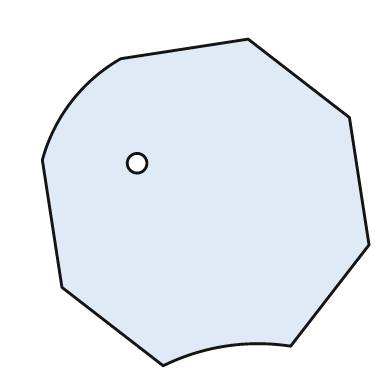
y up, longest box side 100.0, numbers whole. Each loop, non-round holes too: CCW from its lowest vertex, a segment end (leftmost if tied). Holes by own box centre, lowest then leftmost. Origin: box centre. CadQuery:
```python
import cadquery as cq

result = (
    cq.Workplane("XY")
    .moveTo(-13.0, -50.0)
    .threePointArc((6.0, -44.0), (26.0, -44.0))
    .lineTo(50.0, -13.0)
    .lineTo(44.0, 26.0)
    .lineTo(13.0, 50.0)
    .lineTo(-26.0, 44.0)
    .threePointArc((-41.0, 31.0), (-50.0, 13.0))
    .lineTo(-44.0, -26.0)
    .close()
    .moveTo(-21.0, 12.0)
    .circle(3.0)
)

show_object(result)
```